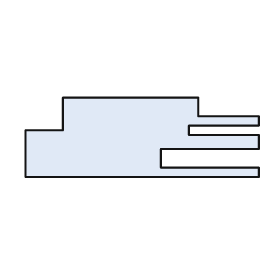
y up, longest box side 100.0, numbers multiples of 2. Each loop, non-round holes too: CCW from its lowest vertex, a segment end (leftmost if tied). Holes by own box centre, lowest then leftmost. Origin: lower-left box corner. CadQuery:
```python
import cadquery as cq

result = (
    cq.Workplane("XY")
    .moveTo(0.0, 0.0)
    .lineTo(100.0, 0.0)
    .lineTo(100.0, 4.0)
    .lineTo(58.0, 4.0)
    .lineTo(58.0, 12.0)
    .lineTo(100.0, 12.0)
    .lineTo(100.0, 18.0)
    .lineTo(70.0, 18.0)
    .lineTo(70.0, 22.0)
    .lineTo(100.0, 22.0)
    .lineTo(100.0, 26.0)
    .lineTo(74.0, 26.0)
    .lineTo(74.0, 34.0)
    .lineTo(16.0, 34.0)
    .lineTo(16.0, 20.0)
    .lineTo(0.0, 20.0)
    .close()
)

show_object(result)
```